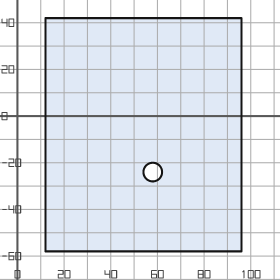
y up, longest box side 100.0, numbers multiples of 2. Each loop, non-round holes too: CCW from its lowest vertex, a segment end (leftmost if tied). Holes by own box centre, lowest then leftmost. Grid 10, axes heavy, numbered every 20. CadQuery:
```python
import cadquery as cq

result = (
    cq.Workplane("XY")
    .moveTo(12.0, -58.0)
    .lineTo(96.0, -58.0)
    .lineTo(96.0, 42.0)
    .lineTo(12.0, 42.0)
    .close()
    .moveTo(58.0, -24.0)
    .circle(4.0)
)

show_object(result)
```